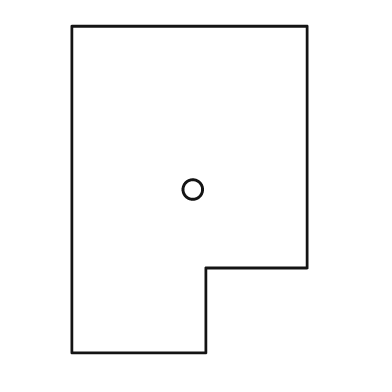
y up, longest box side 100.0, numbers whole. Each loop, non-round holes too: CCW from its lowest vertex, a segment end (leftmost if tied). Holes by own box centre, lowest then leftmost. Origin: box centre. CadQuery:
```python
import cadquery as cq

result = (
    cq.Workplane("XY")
    .moveTo(-36.0, -50.0)
    .lineTo(5.0, -50.0)
    .lineTo(5.0, -24.0)
    .lineTo(36.0, -24.0)
    .lineTo(36.0, 50.0)
    .lineTo(-36.0, 50.0)
    .close()
    .moveTo(1.0, 0.0)
    .circle(3.0)
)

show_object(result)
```